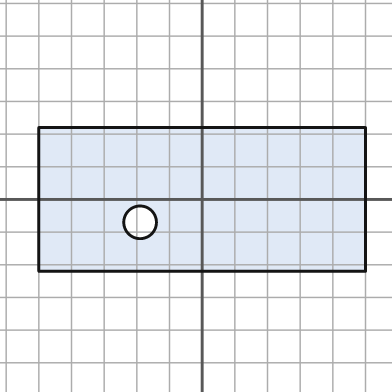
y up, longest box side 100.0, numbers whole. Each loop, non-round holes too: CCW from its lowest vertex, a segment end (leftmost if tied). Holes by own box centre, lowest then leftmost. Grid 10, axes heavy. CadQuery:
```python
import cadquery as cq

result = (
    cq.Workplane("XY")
    .moveTo(-50.0, -22.0)
    .lineTo(50.0, -22.0)
    .lineTo(50.0, 22.0)
    .lineTo(-50.0, 22.0)
    .close()
    .moveTo(-19.0, -7.0)
    .circle(5.0)
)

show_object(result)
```